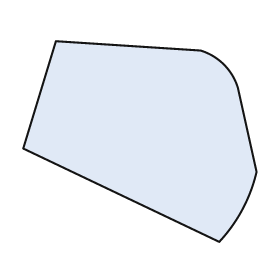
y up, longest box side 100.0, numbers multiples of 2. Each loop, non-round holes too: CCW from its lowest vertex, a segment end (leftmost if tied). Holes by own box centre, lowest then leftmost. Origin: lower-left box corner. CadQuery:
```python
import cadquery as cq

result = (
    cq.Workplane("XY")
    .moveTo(84.0, 0.0)
    .threePointArc((94.0, 14.0), (100.0, 30.0))
    .lineTo(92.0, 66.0)
    .threePointArc((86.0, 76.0), (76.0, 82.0))
    .lineTo(14.0, 86.0)
    .lineTo(0.0, 40.0)
    .close()
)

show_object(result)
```